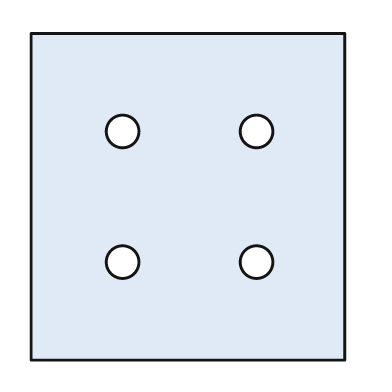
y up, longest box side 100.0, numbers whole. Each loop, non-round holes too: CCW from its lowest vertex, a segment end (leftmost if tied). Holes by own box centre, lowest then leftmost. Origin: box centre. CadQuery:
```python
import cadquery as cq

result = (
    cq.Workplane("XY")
    .moveTo(-48.0, -50.0)
    .lineTo(48.0, -50.0)
    .lineTo(48.0, 50.0)
    .lineTo(-48.0, 50.0)
    .close()
    .moveTo(-20.0, -20.0)
    .circle(5.0)
    .moveTo(21.0, -20.0)
    .circle(5.0)
    .moveTo(-20.0, 20.0)
    .circle(5.0)
    .moveTo(21.0, 20.0)
    .circle(5.0)
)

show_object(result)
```